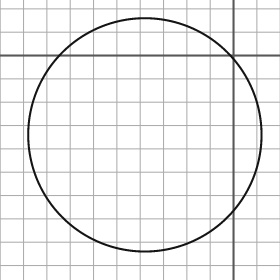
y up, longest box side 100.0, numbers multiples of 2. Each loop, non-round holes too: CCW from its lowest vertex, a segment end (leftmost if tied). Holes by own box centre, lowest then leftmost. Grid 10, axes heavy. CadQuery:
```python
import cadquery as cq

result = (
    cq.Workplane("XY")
    .moveTo(-38.0, -34.0)
    .circle(50.0)
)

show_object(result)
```